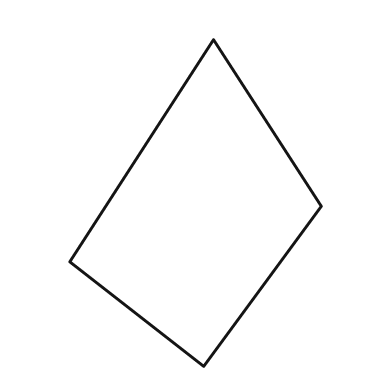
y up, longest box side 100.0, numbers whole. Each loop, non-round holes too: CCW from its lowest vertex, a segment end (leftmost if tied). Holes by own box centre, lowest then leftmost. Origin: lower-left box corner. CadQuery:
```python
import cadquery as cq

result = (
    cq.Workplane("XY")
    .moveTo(41.0, 0.0)
    .lineTo(77.0, 49.0)
    .lineTo(44.0, 100.0)
    .lineTo(0.0, 32.0)
    .close()
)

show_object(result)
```